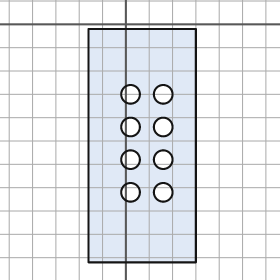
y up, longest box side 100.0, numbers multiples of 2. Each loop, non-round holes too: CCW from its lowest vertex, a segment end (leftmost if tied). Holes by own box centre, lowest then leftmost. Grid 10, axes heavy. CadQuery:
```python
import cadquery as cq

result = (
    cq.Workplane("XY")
    .moveTo(-16.0, -102.0)
    .lineTo(30.0, -102.0)
    .lineTo(30.0, -2.0)
    .lineTo(-16.0, -2.0)
    .close()
    .moveTo(2.0, -72.0)
    .circle(4.0)
    .moveTo(16.0, -72.0)
    .circle(4.0)
    .moveTo(2.0, -58.0)
    .circle(4.0)
    .moveTo(16.0, -58.0)
    .circle(4.0)
    .moveTo(2.0, -44.0)
    .circle(4.0)
    .moveTo(16.0, -44.0)
    .circle(4.0)
    .moveTo(2.0, -30.0)
    .circle(4.0)
    .moveTo(16.0, -30.0)
    .circle(4.0)
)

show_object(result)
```